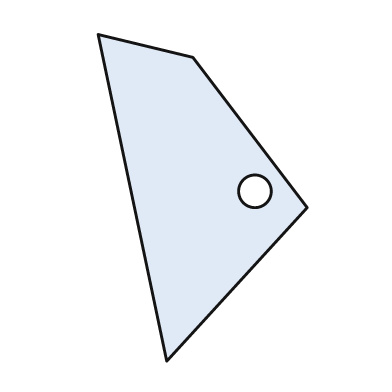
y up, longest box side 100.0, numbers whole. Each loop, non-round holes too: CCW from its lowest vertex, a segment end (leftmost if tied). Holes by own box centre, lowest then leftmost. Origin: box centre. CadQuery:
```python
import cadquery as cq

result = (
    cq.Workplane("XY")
    .moveTo(-11.0, -50.0)
    .lineTo(32.0, -3.0)
    .lineTo(-3.0, 43.0)
    .lineTo(-32.0, 50.0)
    .close()
    .moveTo(16.0, 2.0)
    .circle(5.0)
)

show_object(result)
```